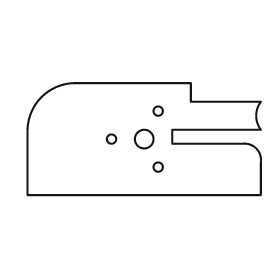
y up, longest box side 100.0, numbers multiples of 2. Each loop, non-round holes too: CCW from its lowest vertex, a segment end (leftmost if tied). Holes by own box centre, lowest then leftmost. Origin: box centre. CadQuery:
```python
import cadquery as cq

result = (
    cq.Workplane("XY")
    .moveTo(-50.0, -24.0)
    .lineTo(50.0, -24.0)
    .lineTo(50.0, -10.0)
    .threePointArc((48.0, -4.0), (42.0, -2.0))
    .lineTo(12.0, -2.0)
    .lineTo(12.0, 4.0)
    .lineTo(50.0, 4.0)
    .threePointArc((48.0, 10.0), (50.0, 16.0))
    .lineTo(20.0, 16.0)
    .lineTo(20.0, 24.0)
    .lineTo(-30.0, 24.0)
    .threePointArc((-44.0, 18.0), (-50.0, 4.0))
    .close()
    .moveTo(6.0, -12.0)
    .circle(2.0)
    .moveTo(-14.0, 0.0)
    .circle(2.0)
    .moveTo(0.0, 0.0)
    .circle(4.0)
    .moveTo(6.0, 12.0)
    .circle(2.0)
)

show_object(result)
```